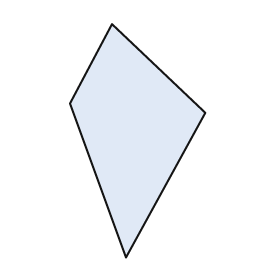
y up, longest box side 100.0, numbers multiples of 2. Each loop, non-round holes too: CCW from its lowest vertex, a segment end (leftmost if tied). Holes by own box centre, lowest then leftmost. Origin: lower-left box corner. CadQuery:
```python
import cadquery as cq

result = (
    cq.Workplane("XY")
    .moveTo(24.0, 0.0)
    .lineTo(58.0, 62.0)
    .lineTo(18.0, 100.0)
    .lineTo(0.0, 66.0)
    .close()
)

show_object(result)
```